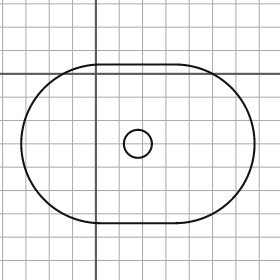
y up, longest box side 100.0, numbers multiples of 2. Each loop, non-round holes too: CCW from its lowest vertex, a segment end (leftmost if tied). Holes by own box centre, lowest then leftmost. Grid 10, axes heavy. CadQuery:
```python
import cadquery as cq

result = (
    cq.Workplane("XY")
    .moveTo(2.0, -64.0)
    .lineTo(34.0, -64.0)
    .threePointArc((68.0, -30.0), (34.0, 4.0))
    .lineTo(2.0, 4.0)
    .threePointArc((-32.0, -30.0), (2.0, -64.0))
    .close()
    .moveTo(18.0, -30.0)
    .circle(6.0)
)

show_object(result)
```